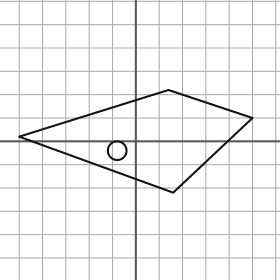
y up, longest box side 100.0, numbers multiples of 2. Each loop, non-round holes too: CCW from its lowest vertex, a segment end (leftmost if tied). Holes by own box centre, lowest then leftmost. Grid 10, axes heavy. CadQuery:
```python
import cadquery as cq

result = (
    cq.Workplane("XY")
    .moveTo(16.0, -22.0)
    .lineTo(50.0, 10.0)
    .lineTo(14.0, 22.0)
    .lineTo(-50.0, 2.0)
    .close()
    .moveTo(-8.0, -4.0)
    .circle(4.0)
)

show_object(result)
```